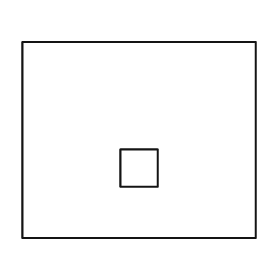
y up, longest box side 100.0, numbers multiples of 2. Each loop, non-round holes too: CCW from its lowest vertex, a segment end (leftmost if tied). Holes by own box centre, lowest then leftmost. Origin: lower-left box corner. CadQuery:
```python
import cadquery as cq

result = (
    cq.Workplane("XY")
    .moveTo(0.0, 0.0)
    .lineTo(100.0, 0.0)
    .lineTo(100.0, 84.0)
    .lineTo(0.0, 84.0)
    .close()
    .moveTo(42.0, 22.0)
    .lineTo(58.0, 22.0)
    .lineTo(58.0, 38.0)
    .lineTo(42.0, 38.0)
    .close()
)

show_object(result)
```